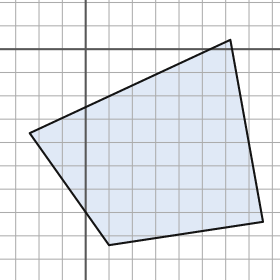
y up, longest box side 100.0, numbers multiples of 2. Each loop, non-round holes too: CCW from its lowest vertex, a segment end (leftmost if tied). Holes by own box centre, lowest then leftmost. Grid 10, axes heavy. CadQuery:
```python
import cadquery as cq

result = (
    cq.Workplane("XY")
    .moveTo(10.0, -84.0)
    .lineTo(76.0, -74.0)
    .lineTo(62.0, 4.0)
    .lineTo(-24.0, -36.0)
    .close()
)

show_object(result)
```